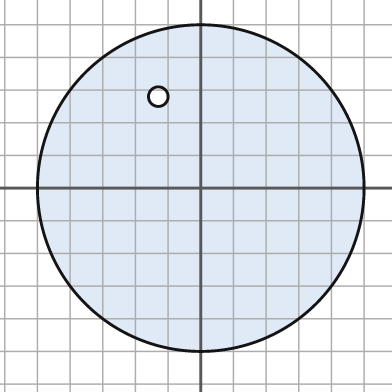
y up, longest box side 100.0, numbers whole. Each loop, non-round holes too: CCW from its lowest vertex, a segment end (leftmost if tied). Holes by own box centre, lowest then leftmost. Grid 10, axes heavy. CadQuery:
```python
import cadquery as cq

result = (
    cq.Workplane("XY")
    .moveTo(0.0, 0.0)
    .circle(50.0)
    .moveTo(-13.0, 28.0)
    .circle(3.0)
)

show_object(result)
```